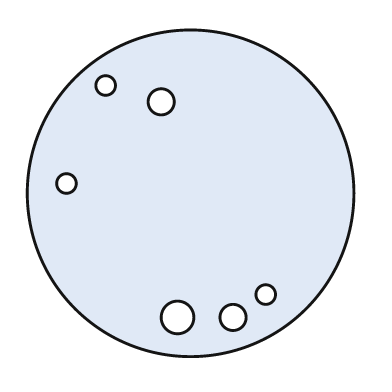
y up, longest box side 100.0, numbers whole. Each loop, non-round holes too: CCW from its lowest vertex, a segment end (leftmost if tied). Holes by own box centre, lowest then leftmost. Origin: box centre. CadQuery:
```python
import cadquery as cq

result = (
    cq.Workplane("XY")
    .moveTo(0.0, 0.0)
    .circle(50.0)
    .moveTo(-4.0, -38.0)
    .circle(5.0)
    .moveTo(13.0, -38.0)
    .circle(4.0)
    .moveTo(23.0, -31.0)
    .circle(3.0)
    .moveTo(-38.0, 3.0)
    .circle(3.0)
    .moveTo(-9.0, 28.0)
    .circle(4.0)
    .moveTo(-26.0, 33.0)
    .circle(3.0)
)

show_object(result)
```